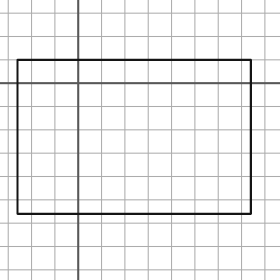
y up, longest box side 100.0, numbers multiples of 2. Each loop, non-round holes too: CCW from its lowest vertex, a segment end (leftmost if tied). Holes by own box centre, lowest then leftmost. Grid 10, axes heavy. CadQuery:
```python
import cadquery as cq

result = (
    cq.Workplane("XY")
    .moveTo(-26.0, -56.0)
    .lineTo(74.0, -56.0)
    .lineTo(74.0, 10.0)
    .lineTo(-26.0, 10.0)
    .close()
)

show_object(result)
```